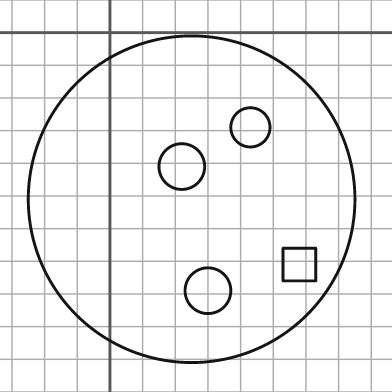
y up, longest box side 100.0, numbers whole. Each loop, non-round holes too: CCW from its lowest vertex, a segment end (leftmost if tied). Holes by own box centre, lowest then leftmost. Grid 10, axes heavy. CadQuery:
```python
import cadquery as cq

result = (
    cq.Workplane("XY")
    .moveTo(25.0, -51.0)
    .circle(50.0)
    .moveTo(30.0, -79.0)
    .circle(7.0)
    .moveTo(53.0, -76.0)
    .lineTo(63.0, -76.0)
    .lineTo(63.0, -66.0)
    .lineTo(53.0, -66.0)
    .close()
    .moveTo(22.0, -41.0)
    .circle(7.0)
    .moveTo(43.0, -29.0)
    .circle(6.0)
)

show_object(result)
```